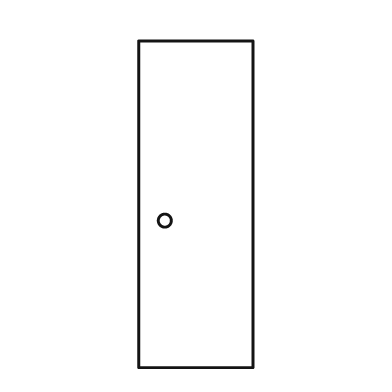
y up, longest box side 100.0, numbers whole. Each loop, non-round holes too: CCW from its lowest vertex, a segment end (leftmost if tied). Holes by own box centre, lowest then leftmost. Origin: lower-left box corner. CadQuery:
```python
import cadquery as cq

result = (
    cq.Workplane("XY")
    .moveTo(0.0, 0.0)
    .lineTo(35.0, 0.0)
    .lineTo(35.0, 100.0)
    .lineTo(0.0, 100.0)
    .close()
    .moveTo(8.0, 45.0)
    .circle(2.0)
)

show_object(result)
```